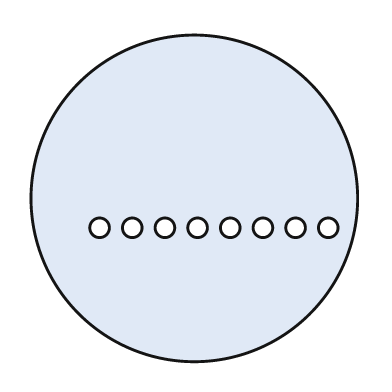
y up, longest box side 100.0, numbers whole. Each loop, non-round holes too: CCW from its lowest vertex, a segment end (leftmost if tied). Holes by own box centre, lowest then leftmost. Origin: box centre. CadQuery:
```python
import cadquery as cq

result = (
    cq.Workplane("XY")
    .moveTo(0.0, 0.0)
    .circle(50.0)
    .moveTo(-29.0, -9.0)
    .circle(3.0)
    .moveTo(-19.0, -9.0)
    .circle(3.0)
    .moveTo(-9.0, -9.0)
    .circle(3.0)
    .moveTo(1.0, -9.0)
    .circle(3.0)
    .moveTo(11.0, -9.0)
    .circle(3.0)
    .moveTo(21.0, -9.0)
    .circle(3.0)
    .moveTo(31.0, -9.0)
    .circle(3.0)
    .moveTo(41.0, -9.0)
    .circle(3.0)
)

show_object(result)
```